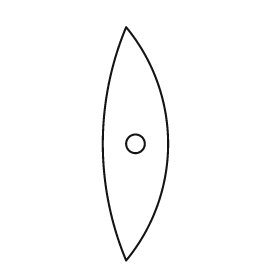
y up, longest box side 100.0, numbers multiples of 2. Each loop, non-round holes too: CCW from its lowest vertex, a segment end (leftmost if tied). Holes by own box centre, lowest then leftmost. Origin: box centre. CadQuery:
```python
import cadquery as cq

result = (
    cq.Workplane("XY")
    .moveTo(-4.0, -50.0)
    .threePointArc((14.0, 0.0), (-4.0, 50.0))
    .threePointArc((-14.0, 0.0), (-4.0, -50.0))
    .close()
    .moveTo(0.0, 0.0)
    .circle(4.0)
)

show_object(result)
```